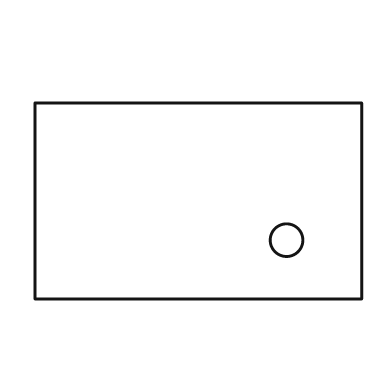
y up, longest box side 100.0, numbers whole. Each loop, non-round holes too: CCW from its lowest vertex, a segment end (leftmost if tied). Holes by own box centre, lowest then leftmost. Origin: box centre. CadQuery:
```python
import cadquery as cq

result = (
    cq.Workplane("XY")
    .moveTo(-50.0, -30.0)
    .lineTo(50.0, -30.0)
    .lineTo(50.0, 30.0)
    .lineTo(-50.0, 30.0)
    .close()
    .moveTo(27.0, -12.0)
    .circle(5.0)
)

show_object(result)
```